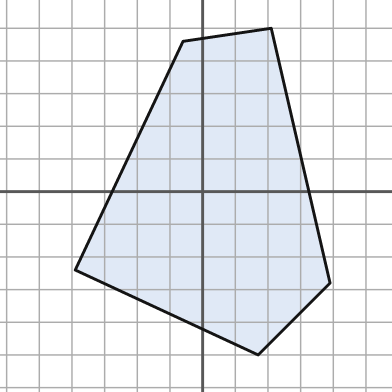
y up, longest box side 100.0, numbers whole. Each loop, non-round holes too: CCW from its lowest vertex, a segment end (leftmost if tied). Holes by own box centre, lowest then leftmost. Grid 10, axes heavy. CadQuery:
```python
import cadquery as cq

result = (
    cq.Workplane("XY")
    .moveTo(17.0, -50.0)
    .lineTo(39.0, -28.0)
    .lineTo(21.0, 50.0)
    .lineTo(-6.0, 46.0)
    .lineTo(-39.0, -24.0)
    .close()
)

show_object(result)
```